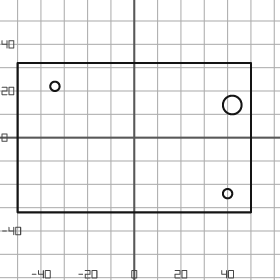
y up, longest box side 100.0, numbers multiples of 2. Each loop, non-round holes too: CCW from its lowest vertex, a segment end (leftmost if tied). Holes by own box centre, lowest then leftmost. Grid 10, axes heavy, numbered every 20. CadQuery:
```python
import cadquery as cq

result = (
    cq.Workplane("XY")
    .moveTo(-50.0, -32.0)
    .lineTo(50.0, -32.0)
    .lineTo(50.0, 32.0)
    .lineTo(-50.0, 32.0)
    .close()
    .moveTo(40.0, -24.0)
    .circle(2.0)
    .moveTo(42.0, 14.0)
    .circle(4.0)
    .moveTo(-34.0, 22.0)
    .circle(2.0)
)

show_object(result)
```